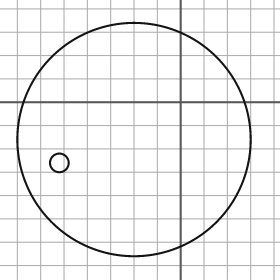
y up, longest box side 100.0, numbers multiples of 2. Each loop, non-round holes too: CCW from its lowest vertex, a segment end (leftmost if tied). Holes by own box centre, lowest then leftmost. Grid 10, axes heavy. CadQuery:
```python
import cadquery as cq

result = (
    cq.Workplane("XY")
    .moveTo(-20.0, -16.0)
    .circle(50.0)
    .moveTo(-52.0, -26.0)
    .circle(4.0)
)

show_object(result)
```